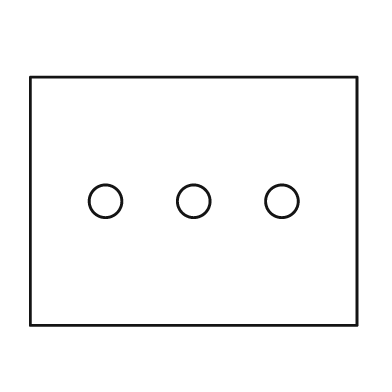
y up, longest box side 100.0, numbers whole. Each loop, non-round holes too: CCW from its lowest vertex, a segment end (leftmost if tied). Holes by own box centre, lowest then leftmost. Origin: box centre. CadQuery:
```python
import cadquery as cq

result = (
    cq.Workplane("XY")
    .moveTo(-50.0, -38.0)
    .lineTo(50.0, -38.0)
    .lineTo(50.0, 38.0)
    .lineTo(-50.0, 38.0)
    .close()
    .moveTo(-27.0, 0.0)
    .circle(5.0)
    .moveTo(0.0, 0.0)
    .circle(5.0)
    .moveTo(27.0, 0.0)
    .circle(5.0)
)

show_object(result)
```